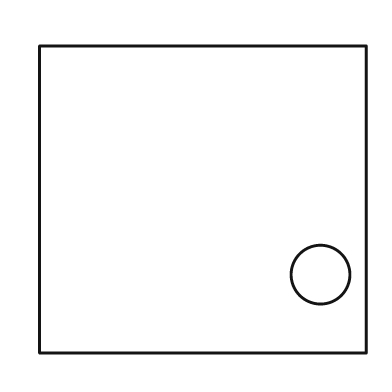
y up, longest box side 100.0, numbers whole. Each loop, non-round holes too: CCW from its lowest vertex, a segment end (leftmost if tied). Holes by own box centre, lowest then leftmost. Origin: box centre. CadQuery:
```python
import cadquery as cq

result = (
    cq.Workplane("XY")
    .moveTo(-50.0, -47.0)
    .lineTo(50.0, -47.0)
    .lineTo(50.0, 47.0)
    .lineTo(-50.0, 47.0)
    .close()
    .moveTo(36.0, -23.0)
    .circle(9.0)
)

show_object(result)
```